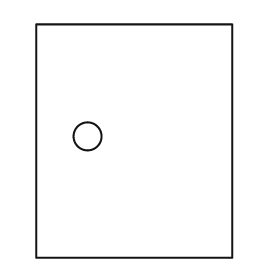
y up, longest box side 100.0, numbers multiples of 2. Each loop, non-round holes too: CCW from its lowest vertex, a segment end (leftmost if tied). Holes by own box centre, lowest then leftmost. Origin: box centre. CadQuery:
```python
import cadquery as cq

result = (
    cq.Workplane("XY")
    .moveTo(-42.0, -50.0)
    .lineTo(42.0, -50.0)
    .lineTo(42.0, 50.0)
    .lineTo(-42.0, 50.0)
    .close()
    .moveTo(-20.0, 2.0)
    .circle(6.0)
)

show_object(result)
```